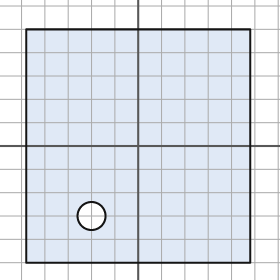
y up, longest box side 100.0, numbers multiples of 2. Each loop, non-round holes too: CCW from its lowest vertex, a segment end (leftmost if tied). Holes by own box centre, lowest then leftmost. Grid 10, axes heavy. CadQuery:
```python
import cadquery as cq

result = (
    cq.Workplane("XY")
    .moveTo(-48.0, -50.0)
    .lineTo(48.0, -50.0)
    .lineTo(48.0, 50.0)
    .lineTo(-48.0, 50.0)
    .close()
    .moveTo(-20.0, -30.0)
    .circle(6.0)
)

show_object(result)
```